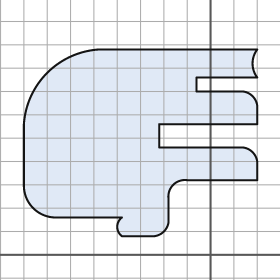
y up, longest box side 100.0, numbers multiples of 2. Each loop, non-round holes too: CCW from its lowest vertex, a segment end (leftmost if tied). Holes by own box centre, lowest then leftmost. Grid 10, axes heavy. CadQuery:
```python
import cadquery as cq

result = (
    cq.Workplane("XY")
    .moveTo(-38.0, 8.0)
    .lineTo(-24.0, 8.0)
    .threePointArc((-20.0, 10.0), (-18.0, 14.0))
    .lineTo(-18.0, 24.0)
    .threePointArc((-16.0, 30.0), (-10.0, 32.0))
    .lineTo(20.0, 32.0)
    .lineTo(20.0, 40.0)
    .threePointArc((18.0, 44.0), (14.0, 46.0))
    .lineTo(-22.0, 46.0)
    .lineTo(-22.0, 56.0)
    .lineTo(20.0, 56.0)
    .lineTo(20.0, 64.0)
    .threePointArc((18.0, 68.0), (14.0, 70.0))
    .lineTo(-6.0, 70.0)
    .lineTo(-6.0, 76.0)
    .lineTo(20.0, 76.0)
    .threePointArc((18.0, 82.0), (20.0, 88.0))
    .lineTo(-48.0, 88.0)
    .threePointArc((-70.0, 78.0), (-80.0, 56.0))
    .lineTo(-80.0, 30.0)
    .threePointArc((-76.0, 20.0), (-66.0, 16.0))
    .lineTo(-38.0, 16.0)
    .threePointArc((-40.0, 12.0), (-38.0, 8.0))
    .close()
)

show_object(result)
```